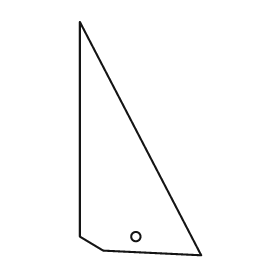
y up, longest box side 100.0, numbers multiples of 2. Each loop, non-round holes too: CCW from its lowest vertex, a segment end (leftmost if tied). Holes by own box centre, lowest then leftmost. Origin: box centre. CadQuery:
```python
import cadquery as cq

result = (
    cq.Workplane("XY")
    .moveTo(26.0, -50.0)
    .lineTo(-26.0, 50.0)
    .lineTo(-26.0, -42.0)
    .lineTo(-16.0, -48.0)
    .close()
    .moveTo(-2.0, -42.0)
    .circle(2.0)
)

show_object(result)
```